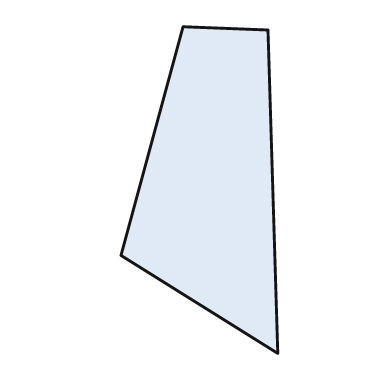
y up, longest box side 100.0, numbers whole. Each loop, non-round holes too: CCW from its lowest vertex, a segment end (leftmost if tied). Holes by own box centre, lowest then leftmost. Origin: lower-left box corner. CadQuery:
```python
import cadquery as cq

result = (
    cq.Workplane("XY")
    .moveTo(48.0, 0.0)
    .lineTo(45.0, 99.0)
    .lineTo(19.0, 100.0)
    .lineTo(0.0, 30.0)
    .close()
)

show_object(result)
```